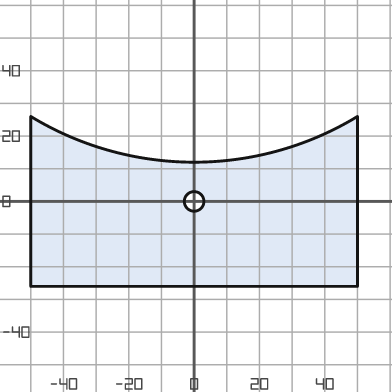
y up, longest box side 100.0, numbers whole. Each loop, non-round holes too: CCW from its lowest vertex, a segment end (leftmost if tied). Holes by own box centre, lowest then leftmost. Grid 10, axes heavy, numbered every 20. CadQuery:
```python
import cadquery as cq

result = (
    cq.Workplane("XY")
    .moveTo(-50.0, -26.0)
    .lineTo(50.0, -26.0)
    .lineTo(50.0, 26.0)
    .threePointArc((0.0, 12.0), (-50.0, 26.0))
    .close()
    .moveTo(0.0, 0.0)
    .circle(3.0)
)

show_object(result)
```